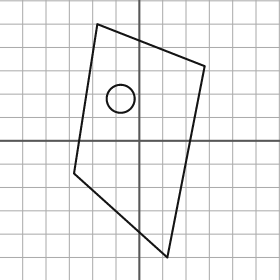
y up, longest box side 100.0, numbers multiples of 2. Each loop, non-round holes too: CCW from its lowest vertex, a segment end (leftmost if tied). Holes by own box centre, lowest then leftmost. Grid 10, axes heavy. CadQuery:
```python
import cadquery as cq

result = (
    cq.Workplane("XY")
    .moveTo(12.0, -50.0)
    .lineTo(28.0, 32.0)
    .lineTo(-18.0, 50.0)
    .lineTo(-28.0, -14.0)
    .close()
    .moveTo(-8.0, 18.0)
    .circle(6.0)
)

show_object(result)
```